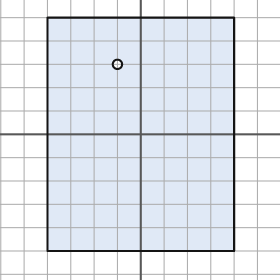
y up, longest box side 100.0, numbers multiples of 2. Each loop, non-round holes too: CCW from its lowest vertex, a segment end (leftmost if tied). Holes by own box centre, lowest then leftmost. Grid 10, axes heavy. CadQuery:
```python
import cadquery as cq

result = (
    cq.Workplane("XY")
    .moveTo(-40.0, -50.0)
    .lineTo(40.0, -50.0)
    .lineTo(40.0, 50.0)
    .lineTo(-40.0, 50.0)
    .close()
    .moveTo(-10.0, 30.0)
    .circle(2.0)
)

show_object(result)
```